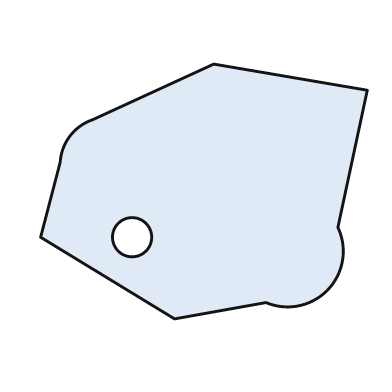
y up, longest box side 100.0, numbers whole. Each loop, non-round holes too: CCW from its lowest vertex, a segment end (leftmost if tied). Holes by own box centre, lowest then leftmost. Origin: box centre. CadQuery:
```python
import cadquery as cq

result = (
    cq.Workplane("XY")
    .moveTo(-9.0, -39.0)
    .lineTo(19.0, -34.0)
    .threePointArc((38.0, -30.0), (41.0, -11.0))
    .lineTo(50.0, 31.0)
    .lineTo(3.0, 39.0)
    .lineTo(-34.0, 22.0)
    .threePointArc((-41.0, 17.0), (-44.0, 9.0))
    .lineTo(-50.0, -14.0)
    .close()
    .moveTo(-22.0, -14.0)
    .circle(6.0)
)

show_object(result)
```